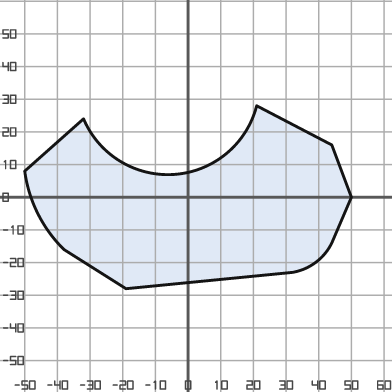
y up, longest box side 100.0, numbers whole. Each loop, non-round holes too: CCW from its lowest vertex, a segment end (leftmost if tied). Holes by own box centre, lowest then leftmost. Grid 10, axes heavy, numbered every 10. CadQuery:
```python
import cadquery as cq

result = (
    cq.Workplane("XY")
    .moveTo(-19.0, -28.0)
    .lineTo(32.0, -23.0)
    .threePointArc((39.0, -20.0), (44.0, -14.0))
    .lineTo(50.0, 0.0)
    .lineTo(44.0, 16.0)
    .lineTo(21.0, 28.0)
    .threePointArc((-4.0, 7.0), (-32.0, 24.0))
    .lineTo(-50.0, 8.0)
    .threePointArc((-46.0, -5.0), (-38.0, -16.0))
    .close()
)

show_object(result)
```